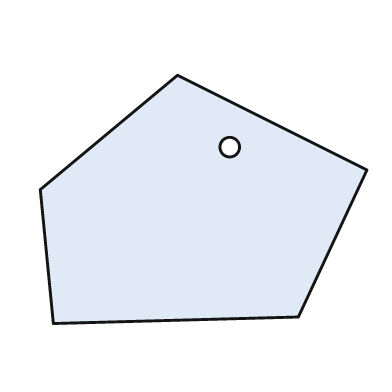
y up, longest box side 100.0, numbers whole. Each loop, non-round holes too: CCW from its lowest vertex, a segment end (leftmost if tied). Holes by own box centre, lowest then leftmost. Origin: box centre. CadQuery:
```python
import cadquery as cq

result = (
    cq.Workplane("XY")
    .moveTo(-46.0, -38.0)
    .lineTo(29.0, -36.0)
    .lineTo(50.0, 9.0)
    .lineTo(-8.0, 38.0)
    .lineTo(-50.0, 3.0)
    .close()
    .moveTo(8.0, 16.0)
    .circle(3.0)
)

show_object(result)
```